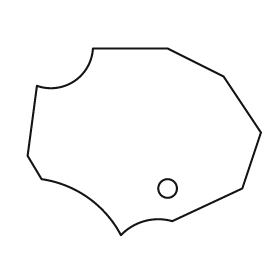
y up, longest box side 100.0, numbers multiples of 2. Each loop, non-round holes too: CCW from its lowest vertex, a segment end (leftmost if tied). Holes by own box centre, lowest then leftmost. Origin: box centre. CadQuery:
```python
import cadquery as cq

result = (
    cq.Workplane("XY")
    .moveTo(-10.0, -40.0)
    .threePointArc((0.0, -34.0), (12.0, -34.0))
    .lineTo(42.0, -20.0)
    .lineTo(50.0, 4.0)
    .lineTo(34.0, 28.0)
    .lineTo(10.0, 40.0)
    .lineTo(-22.0, 40.0)
    .threePointArc((-30.0, 26.0), (-46.0, 24.0))
    .lineTo(-50.0, -6.0)
    .lineTo(-44.0, -16.0)
    .threePointArc((-24.0, -24.0), (-10.0, -40.0))
    .close()
    .moveTo(10.0, -20.0)
    .circle(4.0)
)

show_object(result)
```